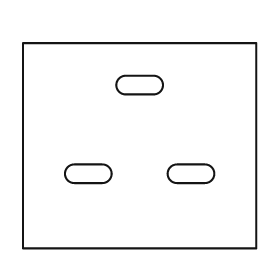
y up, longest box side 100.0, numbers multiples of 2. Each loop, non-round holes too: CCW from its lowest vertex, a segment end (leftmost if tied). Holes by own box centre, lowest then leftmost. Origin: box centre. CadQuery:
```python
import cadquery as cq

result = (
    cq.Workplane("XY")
    .moveTo(-50.0, -44.0)
    .lineTo(50.0, -44.0)
    .lineTo(50.0, 44.0)
    .lineTo(-50.0, 44.0)
    .close()
    .moveTo(-28.0, -16.0)
    .lineTo(-16.0, -16.0)
    .threePointArc((-12.0, -12.0), (-16.0, -8.0))
    .lineTo(-28.0, -8.0)
    .threePointArc((-32.0, -12.0), (-28.0, -16.0))
    .close()
    .moveTo(16.0, -16.0)
    .lineTo(28.0, -16.0)
    .threePointArc((32.0, -12.0), (28.0, -8.0))
    .lineTo(16.0, -8.0)
    .threePointArc((12.0, -12.0), (16.0, -16.0))
    .close()
    .moveTo(-6.0, 22.0)
    .lineTo(6.0, 22.0)
    .threePointArc((10.0, 26.0), (6.0, 30.0))
    .lineTo(-6.0, 30.0)
    .threePointArc((-10.0, 26.0), (-6.0, 22.0))
    .close()
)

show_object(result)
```